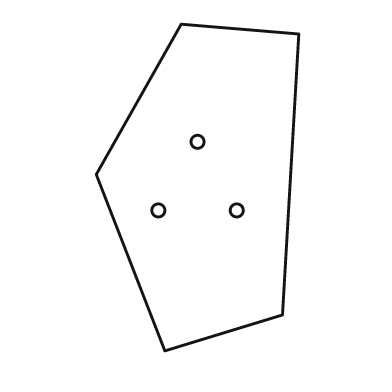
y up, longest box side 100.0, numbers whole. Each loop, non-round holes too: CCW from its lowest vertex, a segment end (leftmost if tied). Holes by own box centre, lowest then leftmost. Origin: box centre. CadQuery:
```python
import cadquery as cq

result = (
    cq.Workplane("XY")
    .moveTo(-10.0, -50.0)
    .lineTo(26.0, -39.0)
    .lineTo(31.0, 47.0)
    .lineTo(-5.0, 50.0)
    .lineTo(-31.0, 4.0)
    .close()
    .moveTo(-12.0, -7.0)
    .circle(2.0)
    .moveTo(12.0, -7.0)
    .circle(2.0)
    .moveTo(0.0, 14.0)
    .circle(2.0)
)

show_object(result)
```